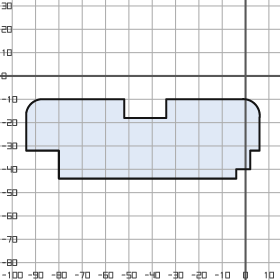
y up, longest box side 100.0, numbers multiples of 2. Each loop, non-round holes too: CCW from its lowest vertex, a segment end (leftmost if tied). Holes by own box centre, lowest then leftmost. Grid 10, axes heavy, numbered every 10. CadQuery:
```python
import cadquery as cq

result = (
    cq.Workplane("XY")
    .moveTo(-80.0, -44.0)
    .lineTo(-4.0, -44.0)
    .lineTo(-4.0, -40.0)
    .lineTo(2.0, -40.0)
    .lineTo(2.0, -32.0)
    .lineTo(6.0, -32.0)
    .lineTo(6.0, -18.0)
    .threePointArc((4.0, -12.0), (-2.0, -10.0))
    .lineTo(-34.0, -10.0)
    .lineTo(-34.0, -18.0)
    .lineTo(-52.0, -18.0)
    .lineTo(-52.0, -10.0)
    .lineTo(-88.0, -10.0)
    .threePointArc((-92.0, -12.0), (-94.0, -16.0))
    .lineTo(-94.0, -32.0)
    .lineTo(-80.0, -32.0)
    .close()
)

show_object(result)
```